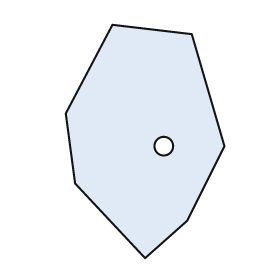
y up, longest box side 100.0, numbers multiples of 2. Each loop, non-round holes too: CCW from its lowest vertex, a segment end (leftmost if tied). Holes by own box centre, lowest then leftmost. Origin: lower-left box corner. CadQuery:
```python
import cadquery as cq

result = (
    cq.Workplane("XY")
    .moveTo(34.0, 0.0)
    .lineTo(52.0, 16.0)
    .lineTo(68.0, 48.0)
    .lineTo(54.0, 96.0)
    .lineTo(20.0, 100.0)
    .lineTo(0.0, 62.0)
    .lineTo(4.0, 32.0)
    .close()
    .moveTo(42.0, 48.0)
    .circle(4.0)
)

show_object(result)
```